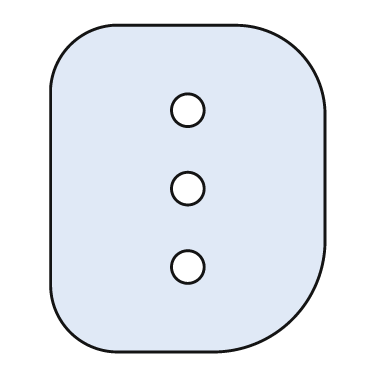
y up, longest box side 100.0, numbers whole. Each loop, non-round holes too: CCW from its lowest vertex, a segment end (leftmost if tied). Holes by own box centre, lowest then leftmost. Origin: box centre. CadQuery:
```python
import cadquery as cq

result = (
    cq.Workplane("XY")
    .moveTo(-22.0, -50.0)
    .lineTo(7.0, -50.0)
    .threePointArc((32.0, -40.0), (42.0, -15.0))
    .lineTo(42.0, 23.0)
    .threePointArc((34.0, 42.0), (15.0, 50.0))
    .lineTo(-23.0, 50.0)
    .threePointArc((-36.0, 44.0), (-42.0, 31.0))
    .lineTo(-42.0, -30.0)
    .threePointArc((-36.0, -44.0), (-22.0, -50.0))
    .close()
    .moveTo(0.0, -24.0)
    .circle(5.0)
    .moveTo(0.0, 0.0)
    .circle(5.0)
    .moveTo(0.0, 24.0)
    .circle(5.0)
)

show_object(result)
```